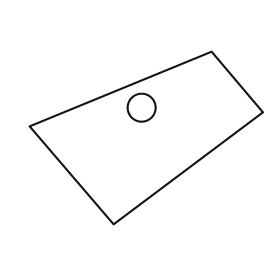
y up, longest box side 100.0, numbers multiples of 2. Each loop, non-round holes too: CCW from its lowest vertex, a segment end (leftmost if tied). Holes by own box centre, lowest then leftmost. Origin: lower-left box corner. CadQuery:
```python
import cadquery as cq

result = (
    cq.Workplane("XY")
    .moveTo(36.0, 0.0)
    .lineTo(100.0, 48.0)
    .lineTo(78.0, 74.0)
    .lineTo(0.0, 42.0)
    .close()
    .moveTo(48.0, 50.0)
    .circle(6.0)
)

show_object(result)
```